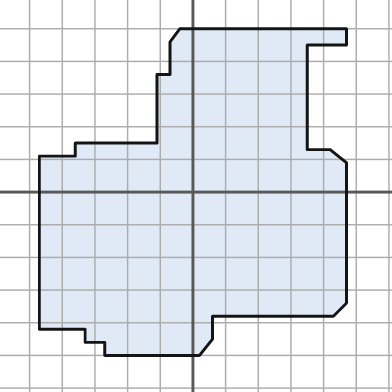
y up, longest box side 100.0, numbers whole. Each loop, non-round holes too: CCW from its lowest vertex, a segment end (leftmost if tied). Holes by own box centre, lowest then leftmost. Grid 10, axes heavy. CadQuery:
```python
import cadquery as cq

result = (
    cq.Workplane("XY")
    .moveTo(-27.0, -50.0)
    .lineTo(2.0, -50.0)
    .lineTo(6.0, -45.0)
    .lineTo(6.0, -38.0)
    .lineTo(43.0, -38.0)
    .lineTo(47.0, -34.0)
    .lineTo(47.0, 9.0)
    .lineTo(42.0, 13.0)
    .lineTo(35.0, 13.0)
    .lineTo(35.0, 45.0)
    .lineTo(47.0, 45.0)
    .lineTo(47.0, 50.0)
    .lineTo(-4.0, 50.0)
    .lineTo(-7.0, 46.0)
    .lineTo(-7.0, 36.0)
    .lineTo(-11.0, 36.0)
    .lineTo(-11.0, 15.0)
    .lineTo(-36.0, 15.0)
    .lineTo(-36.0, 11.0)
    .lineTo(-47.0, 11.0)
    .lineTo(-47.0, -42.0)
    .lineTo(-33.0, -42.0)
    .lineTo(-33.0, -46.0)
    .lineTo(-27.0, -46.0)
    .close()
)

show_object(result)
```